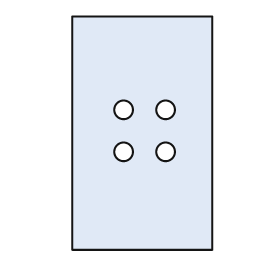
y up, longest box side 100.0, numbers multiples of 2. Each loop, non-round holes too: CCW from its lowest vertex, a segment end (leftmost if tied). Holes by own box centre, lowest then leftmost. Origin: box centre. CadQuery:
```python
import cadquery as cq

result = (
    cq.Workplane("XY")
    .moveTo(-30.0, -50.0)
    .lineTo(30.0, -50.0)
    .lineTo(30.0, 50.0)
    .lineTo(-30.0, 50.0)
    .close()
    .moveTo(-8.0, -8.0)
    .circle(4.0)
    .moveTo(10.0, -8.0)
    .circle(4.0)
    .moveTo(-8.0, 10.0)
    .circle(4.0)
    .moveTo(10.0, 10.0)
    .circle(4.0)
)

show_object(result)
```